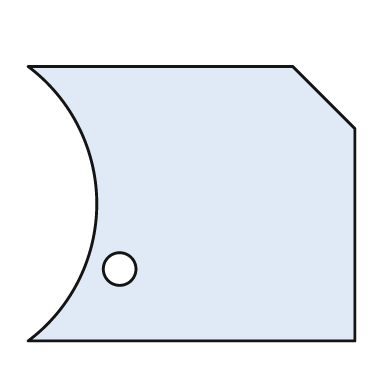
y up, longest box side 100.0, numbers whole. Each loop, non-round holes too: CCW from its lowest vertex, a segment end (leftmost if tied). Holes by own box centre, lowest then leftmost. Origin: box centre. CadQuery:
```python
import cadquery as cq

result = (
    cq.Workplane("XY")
    .moveTo(-50.0, -42.0)
    .lineTo(50.0, -42.0)
    .lineTo(50.0, 23.0)
    .lineTo(31.0, 42.0)
    .lineTo(-50.0, 42.0)
    .threePointArc((-29.0, 0.0), (-50.0, -42.0))
    .close()
    .moveTo(-22.0, -20.0)
    .circle(5.0)
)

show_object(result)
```